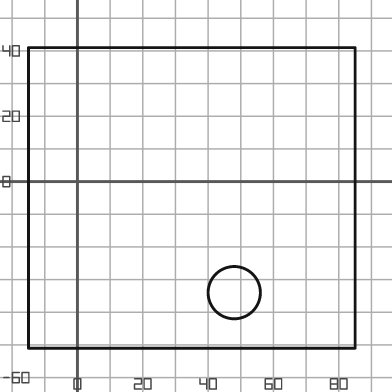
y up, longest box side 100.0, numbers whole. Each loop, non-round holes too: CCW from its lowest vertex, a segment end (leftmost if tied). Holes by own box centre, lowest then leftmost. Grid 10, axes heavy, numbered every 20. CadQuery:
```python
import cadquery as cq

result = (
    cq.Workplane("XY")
    .moveTo(-15.0, -51.0)
    .lineTo(85.0, -51.0)
    .lineTo(85.0, 41.0)
    .lineTo(-15.0, 41.0)
    .close()
    .moveTo(48.0, -34.0)
    .circle(8.0)
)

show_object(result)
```